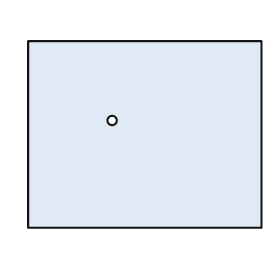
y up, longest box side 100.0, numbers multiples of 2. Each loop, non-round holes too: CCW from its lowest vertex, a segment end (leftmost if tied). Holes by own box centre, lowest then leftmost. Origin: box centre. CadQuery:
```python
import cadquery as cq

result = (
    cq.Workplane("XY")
    .moveTo(-50.0, -40.0)
    .lineTo(50.0, -40.0)
    .lineTo(50.0, 40.0)
    .lineTo(-50.0, 40.0)
    .close()
    .moveTo(-14.0, 6.0)
    .circle(2.0)
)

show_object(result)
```